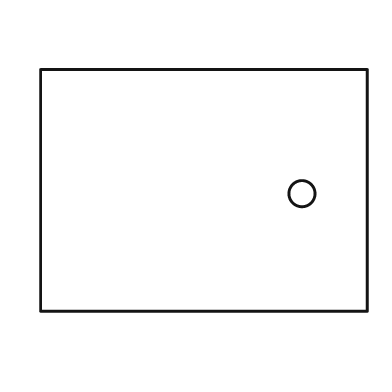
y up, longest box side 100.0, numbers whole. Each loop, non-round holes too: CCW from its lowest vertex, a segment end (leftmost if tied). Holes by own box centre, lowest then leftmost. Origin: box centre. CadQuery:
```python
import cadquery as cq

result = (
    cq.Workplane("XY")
    .moveTo(-50.0, -37.0)
    .lineTo(50.0, -37.0)
    .lineTo(50.0, 37.0)
    .lineTo(-50.0, 37.0)
    .close()
    .moveTo(30.0, -1.0)
    .circle(4.0)
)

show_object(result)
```